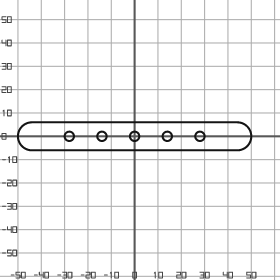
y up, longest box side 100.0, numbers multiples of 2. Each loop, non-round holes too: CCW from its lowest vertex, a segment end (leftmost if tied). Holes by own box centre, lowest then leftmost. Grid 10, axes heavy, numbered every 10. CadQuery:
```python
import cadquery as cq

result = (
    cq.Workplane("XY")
    .moveTo(-44.0, -6.0)
    .lineTo(44.0, -6.0)
    .threePointArc((50.0, 0.0), (44.0, 6.0))
    .lineTo(-44.0, 6.0)
    .threePointArc((-50.0, 0.0), (-44.0, -6.0))
    .close()
    .moveTo(-28.0, 0.0)
    .circle(2.0)
    .moveTo(-14.0, 0.0)
    .circle(2.0)
    .moveTo(0.0, 0.0)
    .circle(2.0)
    .moveTo(14.0, 0.0)
    .circle(2.0)
    .moveTo(28.0, 0.0)
    .circle(2.0)
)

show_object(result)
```